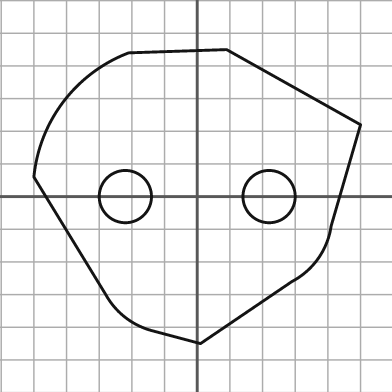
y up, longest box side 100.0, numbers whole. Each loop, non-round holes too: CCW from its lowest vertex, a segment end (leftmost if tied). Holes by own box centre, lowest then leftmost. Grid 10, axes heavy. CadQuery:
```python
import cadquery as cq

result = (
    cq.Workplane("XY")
    .moveTo(1.0, -45.0)
    .lineTo(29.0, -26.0)
    .threePointArc((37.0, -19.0), (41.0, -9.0))
    .lineTo(50.0, 22.0)
    .lineTo(9.0, 45.0)
    .lineTo(-21.0, 44.0)
    .threePointArc((-41.0, 29.0), (-50.0, 6.0))
    .lineTo(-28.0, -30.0)
    .threePointArc((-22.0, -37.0), (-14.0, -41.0))
    .close()
    .moveTo(-22.0, 0.0)
    .circle(8.0)
    .moveTo(22.0, 0.0)
    .circle(8.0)
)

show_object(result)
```